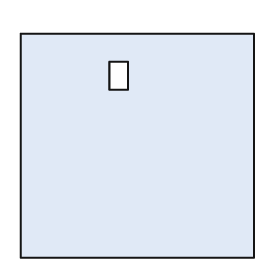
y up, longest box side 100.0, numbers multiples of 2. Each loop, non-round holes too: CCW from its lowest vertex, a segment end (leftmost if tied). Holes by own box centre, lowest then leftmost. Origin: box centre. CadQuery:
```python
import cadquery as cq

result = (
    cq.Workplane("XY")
    .moveTo(-50.0, -48.0)
    .lineTo(50.0, -48.0)
    .lineTo(50.0, 48.0)
    .lineTo(-50.0, 48.0)
    .close()
    .moveTo(-12.0, 24.0)
    .lineTo(-4.0, 24.0)
    .lineTo(-4.0, 36.0)
    .lineTo(-12.0, 36.0)
    .close()
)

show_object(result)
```